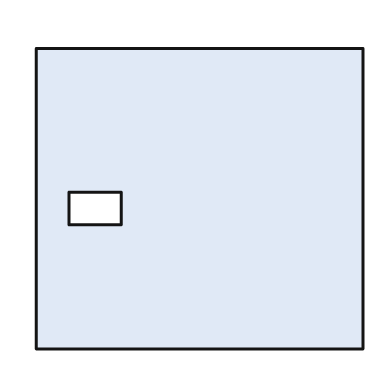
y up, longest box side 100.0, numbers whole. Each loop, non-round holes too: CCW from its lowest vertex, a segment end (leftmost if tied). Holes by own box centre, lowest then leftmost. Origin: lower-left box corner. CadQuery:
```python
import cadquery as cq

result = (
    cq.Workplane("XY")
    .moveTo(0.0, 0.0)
    .lineTo(100.0, 0.0)
    .lineTo(100.0, 92.0)
    .lineTo(0.0, 92.0)
    .close()
    .moveTo(10.0, 38.0)
    .lineTo(26.0, 38.0)
    .lineTo(26.0, 48.0)
    .lineTo(10.0, 48.0)
    .close()
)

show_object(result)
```